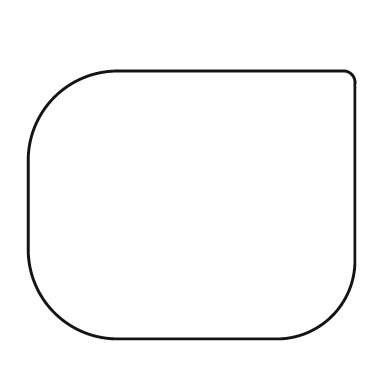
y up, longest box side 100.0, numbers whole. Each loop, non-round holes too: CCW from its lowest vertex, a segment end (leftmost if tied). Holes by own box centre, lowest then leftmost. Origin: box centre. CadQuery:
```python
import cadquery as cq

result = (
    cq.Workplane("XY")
    .moveTo(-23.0, -41.0)
    .lineTo(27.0, -41.0)
    .threePointArc((43.0, -34.0), (50.0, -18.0))
    .lineTo(50.0, 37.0)
    .threePointArc((49.0, 40.0), (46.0, 41.0))
    .lineTo(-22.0, 41.0)
    .threePointArc((-42.0, 33.0), (-50.0, 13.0))
    .lineTo(-50.0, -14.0)
    .threePointArc((-42.0, -33.0), (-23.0, -41.0))
    .close()
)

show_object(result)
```